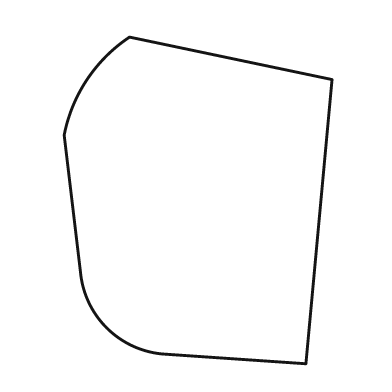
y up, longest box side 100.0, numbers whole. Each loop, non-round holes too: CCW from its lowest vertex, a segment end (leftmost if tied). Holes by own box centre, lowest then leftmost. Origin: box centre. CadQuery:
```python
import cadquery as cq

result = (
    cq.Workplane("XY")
    .moveTo(33.0, -50.0)
    .lineTo(41.0, 37.0)
    .lineTo(-21.0, 50.0)
    .threePointArc((-34.0, 37.0), (-41.0, 20.0))
    .lineTo(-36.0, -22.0)
    .threePointArc((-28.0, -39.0), (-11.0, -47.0))
    .close()
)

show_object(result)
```